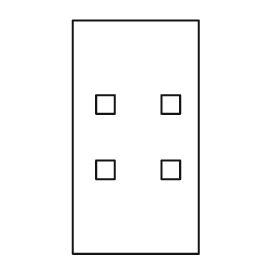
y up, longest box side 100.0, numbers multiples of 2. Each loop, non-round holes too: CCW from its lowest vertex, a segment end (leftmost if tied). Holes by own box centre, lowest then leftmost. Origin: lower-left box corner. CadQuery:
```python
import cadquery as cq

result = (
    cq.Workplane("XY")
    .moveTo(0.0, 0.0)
    .lineTo(54.0, 0.0)
    .lineTo(54.0, 100.0)
    .lineTo(0.0, 100.0)
    .close()
    .moveTo(10.0, 32.0)
    .lineTo(18.0, 32.0)
    .lineTo(18.0, 40.0)
    .lineTo(10.0, 40.0)
    .close()
    .moveTo(38.0, 32.0)
    .lineTo(46.0, 32.0)
    .lineTo(46.0, 40.0)
    .lineTo(38.0, 40.0)
    .close()
    .moveTo(10.0, 60.0)
    .lineTo(18.0, 60.0)
    .lineTo(18.0, 68.0)
    .lineTo(10.0, 68.0)
    .close()
    .moveTo(38.0, 60.0)
    .lineTo(46.0, 60.0)
    .lineTo(46.0, 68.0)
    .lineTo(38.0, 68.0)
    .close()
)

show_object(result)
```